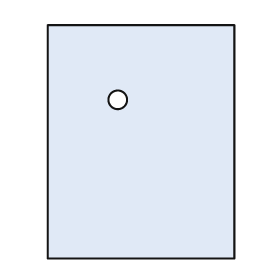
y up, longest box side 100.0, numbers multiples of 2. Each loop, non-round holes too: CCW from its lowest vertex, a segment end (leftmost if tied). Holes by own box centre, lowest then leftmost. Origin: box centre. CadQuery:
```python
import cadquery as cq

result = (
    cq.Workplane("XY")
    .moveTo(-40.0, -50.0)
    .lineTo(40.0, -50.0)
    .lineTo(40.0, 50.0)
    .lineTo(-40.0, 50.0)
    .close()
    .moveTo(-10.0, 18.0)
    .circle(4.0)
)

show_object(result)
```